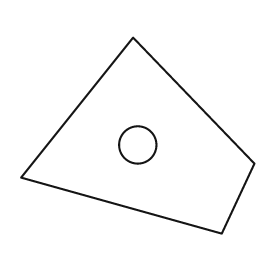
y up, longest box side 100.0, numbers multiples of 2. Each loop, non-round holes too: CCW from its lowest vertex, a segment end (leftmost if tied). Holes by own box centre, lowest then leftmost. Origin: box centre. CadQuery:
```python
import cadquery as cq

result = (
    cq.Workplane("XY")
    .moveTo(36.0, -42.0)
    .lineTo(50.0, -12.0)
    .lineTo(-2.0, 42.0)
    .lineTo(-50.0, -18.0)
    .close()
    .moveTo(0.0, -4.0)
    .circle(8.0)
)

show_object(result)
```